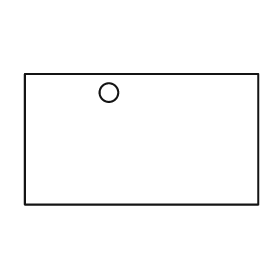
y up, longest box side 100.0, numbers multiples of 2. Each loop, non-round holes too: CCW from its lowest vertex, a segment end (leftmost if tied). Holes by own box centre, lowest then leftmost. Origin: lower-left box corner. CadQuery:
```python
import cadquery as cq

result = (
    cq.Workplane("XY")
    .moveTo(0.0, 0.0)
    .lineTo(100.0, 0.0)
    .lineTo(100.0, 56.0)
    .lineTo(0.0, 56.0)
    .close()
    .moveTo(36.0, 48.0)
    .circle(4.0)
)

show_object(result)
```